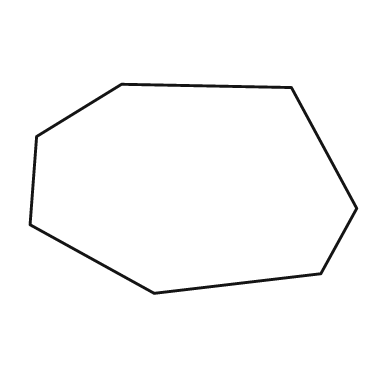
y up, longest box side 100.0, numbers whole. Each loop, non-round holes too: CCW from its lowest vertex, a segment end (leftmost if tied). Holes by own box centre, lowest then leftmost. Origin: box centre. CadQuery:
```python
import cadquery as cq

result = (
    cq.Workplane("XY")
    .moveTo(-12.0, -32.0)
    .lineTo(39.0, -26.0)
    .lineTo(50.0, -6.0)
    .lineTo(30.0, 31.0)
    .lineTo(-22.0, 32.0)
    .lineTo(-48.0, 16.0)
    .lineTo(-50.0, -11.0)
    .close()
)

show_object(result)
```